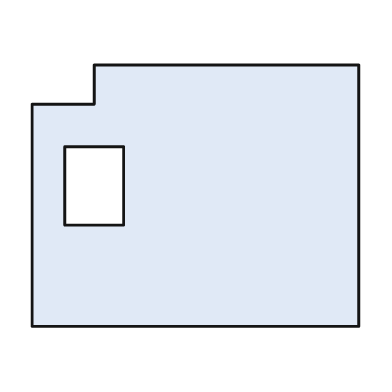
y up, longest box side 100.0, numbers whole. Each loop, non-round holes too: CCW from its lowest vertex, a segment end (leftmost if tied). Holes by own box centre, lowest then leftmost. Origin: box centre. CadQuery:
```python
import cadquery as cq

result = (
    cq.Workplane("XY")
    .moveTo(-50.0, -40.0)
    .lineTo(50.0, -40.0)
    .lineTo(50.0, 40.0)
    .lineTo(-31.0, 40.0)
    .lineTo(-31.0, 28.0)
    .lineTo(-50.0, 28.0)
    .close()
    .moveTo(-40.0, -9.0)
    .lineTo(-22.0, -9.0)
    .lineTo(-22.0, 15.0)
    .lineTo(-40.0, 15.0)
    .close()
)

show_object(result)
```